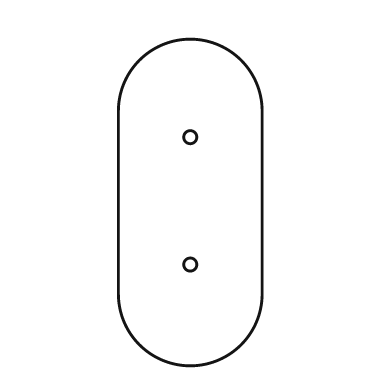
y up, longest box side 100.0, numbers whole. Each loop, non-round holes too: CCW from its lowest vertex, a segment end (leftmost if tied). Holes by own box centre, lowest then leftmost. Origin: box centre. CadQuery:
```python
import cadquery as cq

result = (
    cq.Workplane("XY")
    .moveTo(-22.0, -28.0)
    .threePointArc((0.0, -50.0), (22.0, -28.0))
    .lineTo(22.0, 28.0)
    .threePointArc((0.0, 50.0), (-22.0, 28.0))
    .close()
    .moveTo(0.0, -19.0)
    .circle(2.0)
    .moveTo(0.0, 20.0)
    .circle(2.0)
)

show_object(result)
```